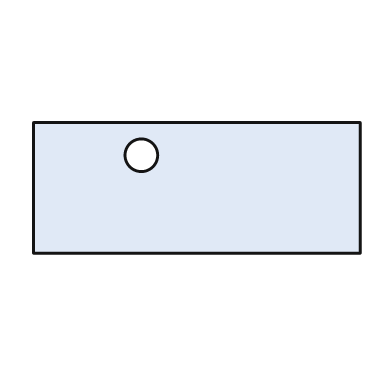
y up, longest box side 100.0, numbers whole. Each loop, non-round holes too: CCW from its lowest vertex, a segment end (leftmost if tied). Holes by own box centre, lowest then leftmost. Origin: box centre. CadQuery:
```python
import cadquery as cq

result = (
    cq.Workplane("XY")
    .moveTo(-50.0, -20.0)
    .lineTo(50.0, -20.0)
    .lineTo(50.0, 20.0)
    .lineTo(-50.0, 20.0)
    .close()
    .moveTo(-17.0, 10.0)
    .circle(5.0)
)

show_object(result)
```